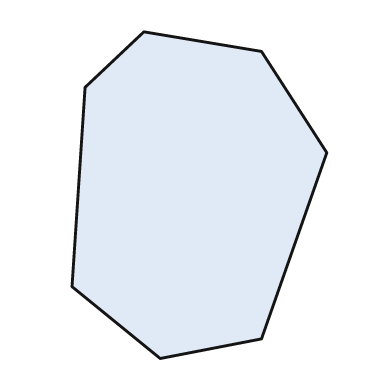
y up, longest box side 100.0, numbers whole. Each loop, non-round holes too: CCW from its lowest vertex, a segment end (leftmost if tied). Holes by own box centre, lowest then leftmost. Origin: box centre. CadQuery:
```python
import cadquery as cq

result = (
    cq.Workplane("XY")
    .moveTo(-12.0, -50.0)
    .lineTo(19.0, -44.0)
    .lineTo(39.0, 13.0)
    .lineTo(19.0, 44.0)
    .lineTo(-17.0, 50.0)
    .lineTo(-35.0, 33.0)
    .lineTo(-39.0, -28.0)
    .close()
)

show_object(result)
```